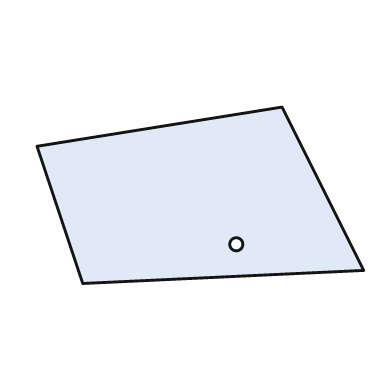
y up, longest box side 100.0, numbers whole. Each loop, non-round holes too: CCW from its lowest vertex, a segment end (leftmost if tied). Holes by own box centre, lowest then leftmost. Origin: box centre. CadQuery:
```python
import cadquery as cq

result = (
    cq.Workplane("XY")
    .moveTo(-36.0, -27.0)
    .lineTo(50.0, -23.0)
    .lineTo(25.0, 27.0)
    .lineTo(-50.0, 15.0)
    .close()
    .moveTo(11.0, -15.0)
    .circle(2.0)
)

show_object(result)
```